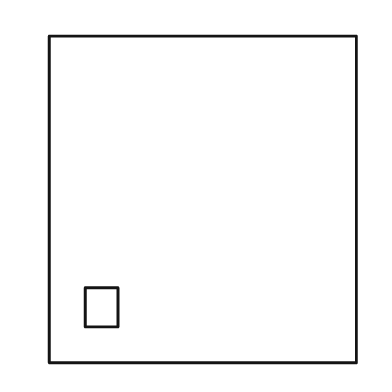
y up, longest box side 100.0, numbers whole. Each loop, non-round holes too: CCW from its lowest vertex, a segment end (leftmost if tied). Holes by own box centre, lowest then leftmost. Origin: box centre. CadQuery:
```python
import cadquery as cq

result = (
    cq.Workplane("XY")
    .moveTo(-47.0, -50.0)
    .lineTo(47.0, -50.0)
    .lineTo(47.0, 50.0)
    .lineTo(-47.0, 50.0)
    .close()
    .moveTo(-36.0, -39.0)
    .lineTo(-26.0, -39.0)
    .lineTo(-26.0, -27.0)
    .lineTo(-36.0, -27.0)
    .close()
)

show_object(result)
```